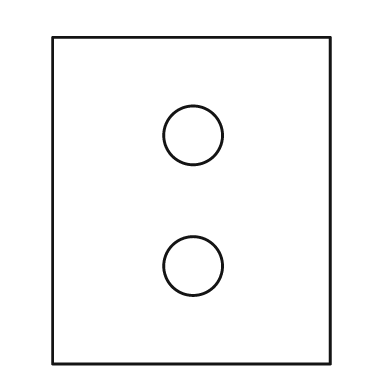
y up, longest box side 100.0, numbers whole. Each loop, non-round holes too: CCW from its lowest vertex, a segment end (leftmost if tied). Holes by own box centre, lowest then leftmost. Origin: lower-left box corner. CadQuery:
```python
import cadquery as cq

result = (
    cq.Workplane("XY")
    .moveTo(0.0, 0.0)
    .lineTo(85.0, 0.0)
    .lineTo(85.0, 100.0)
    .lineTo(0.0, 100.0)
    .close()
    .moveTo(43.0, 30.0)
    .circle(9.0)
    .moveTo(43.0, 70.0)
    .circle(9.0)
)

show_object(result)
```